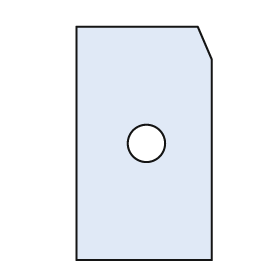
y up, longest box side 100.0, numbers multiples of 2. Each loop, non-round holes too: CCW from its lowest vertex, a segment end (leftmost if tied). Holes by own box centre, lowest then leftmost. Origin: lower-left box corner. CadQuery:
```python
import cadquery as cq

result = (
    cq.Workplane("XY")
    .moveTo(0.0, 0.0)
    .lineTo(58.0, 0.0)
    .lineTo(58.0, 86.0)
    .lineTo(52.0, 100.0)
    .lineTo(0.0, 100.0)
    .close()
    .moveTo(30.0, 50.0)
    .circle(8.0)
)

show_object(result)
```